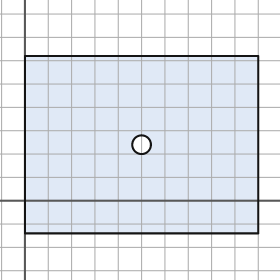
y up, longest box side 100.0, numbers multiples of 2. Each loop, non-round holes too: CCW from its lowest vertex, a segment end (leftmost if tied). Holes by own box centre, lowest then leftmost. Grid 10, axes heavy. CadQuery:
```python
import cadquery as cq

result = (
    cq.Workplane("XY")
    .moveTo(0.0, -14.0)
    .lineTo(100.0, -14.0)
    .lineTo(100.0, 62.0)
    .lineTo(0.0, 62.0)
    .close()
    .moveTo(50.0, 24.0)
    .circle(4.0)
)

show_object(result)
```